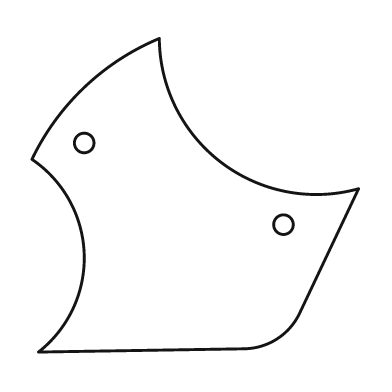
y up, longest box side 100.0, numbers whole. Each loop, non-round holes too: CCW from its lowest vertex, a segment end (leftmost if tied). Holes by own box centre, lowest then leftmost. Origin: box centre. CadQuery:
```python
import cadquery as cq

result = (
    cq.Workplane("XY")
    .moveTo(-48.0, -48.0)
    .lineTo(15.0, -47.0)
    .threePointArc((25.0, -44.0), (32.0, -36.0))
    .lineTo(50.0, 2.0)
    .threePointArc((8.0, 10.0), (-11.0, 48.0))
    .threePointArc((-34.0, 33.0), (-50.0, 11.0))
    .threePointArc((-34.0, -18.0), (-48.0, -48.0))
    .close()
    .moveTo(27.0, -9.0)
    .circle(3.0)
    .moveTo(-34.0, 16.0)
    .circle(3.0)
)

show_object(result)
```